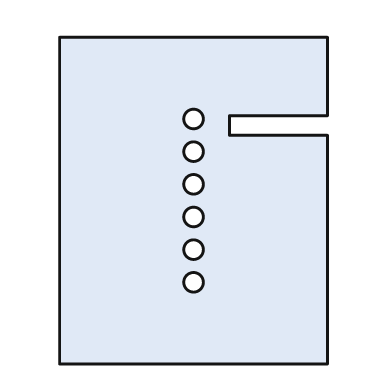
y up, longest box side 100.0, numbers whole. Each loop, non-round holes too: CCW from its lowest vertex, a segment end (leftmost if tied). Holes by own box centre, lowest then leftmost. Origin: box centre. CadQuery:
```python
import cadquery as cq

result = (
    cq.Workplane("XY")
    .moveTo(-41.0, -50.0)
    .lineTo(41.0, -50.0)
    .lineTo(41.0, 20.0)
    .lineTo(11.0, 20.0)
    .lineTo(11.0, 26.0)
    .lineTo(41.0, 26.0)
    .lineTo(41.0, 50.0)
    .lineTo(-41.0, 50.0)
    .close()
    .moveTo(0.0, -25.0)
    .circle(3.0)
    .moveTo(0.0, -15.0)
    .circle(3.0)
    .moveTo(0.0, -5.0)
    .circle(3.0)
    .moveTo(0.0, 5.0)
    .circle(3.0)
    .moveTo(0.0, 15.0)
    .circle(3.0)
    .moveTo(0.0, 25.0)
    .circle(3.0)
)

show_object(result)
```